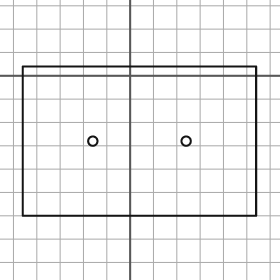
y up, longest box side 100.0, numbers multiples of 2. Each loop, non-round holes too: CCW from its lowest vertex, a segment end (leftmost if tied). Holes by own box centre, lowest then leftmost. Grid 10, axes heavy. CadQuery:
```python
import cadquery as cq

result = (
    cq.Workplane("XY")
    .moveTo(-46.0, -60.0)
    .lineTo(54.0, -60.0)
    .lineTo(54.0, 4.0)
    .lineTo(-46.0, 4.0)
    .close()
    .moveTo(-16.0, -28.0)
    .circle(2.0)
    .moveTo(24.0, -28.0)
    .circle(2.0)
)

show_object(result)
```